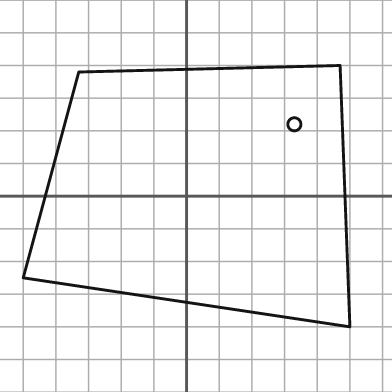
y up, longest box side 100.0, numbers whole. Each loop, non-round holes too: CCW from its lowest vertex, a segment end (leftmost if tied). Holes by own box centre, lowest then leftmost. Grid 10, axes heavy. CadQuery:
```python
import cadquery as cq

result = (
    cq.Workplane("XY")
    .moveTo(50.0, -40.0)
    .lineTo(47.0, 40.0)
    .lineTo(-33.0, 38.0)
    .lineTo(-50.0, -25.0)
    .close()
    .moveTo(33.0, 22.0)
    .circle(2.0)
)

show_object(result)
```